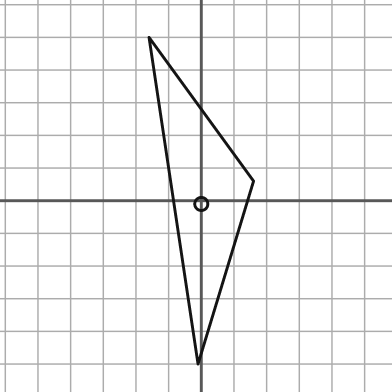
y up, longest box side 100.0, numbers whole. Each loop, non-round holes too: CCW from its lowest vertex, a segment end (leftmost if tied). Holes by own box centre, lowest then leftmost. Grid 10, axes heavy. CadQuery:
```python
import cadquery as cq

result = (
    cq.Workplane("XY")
    .moveTo(-1.0, -50.0)
    .lineTo(16.0, 6.0)
    .lineTo(-16.0, 50.0)
    .close()
    .moveTo(0.0, -1.0)
    .circle(2.0)
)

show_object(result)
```